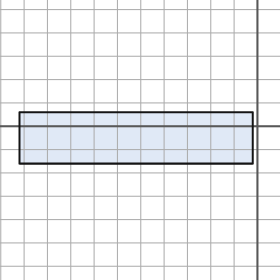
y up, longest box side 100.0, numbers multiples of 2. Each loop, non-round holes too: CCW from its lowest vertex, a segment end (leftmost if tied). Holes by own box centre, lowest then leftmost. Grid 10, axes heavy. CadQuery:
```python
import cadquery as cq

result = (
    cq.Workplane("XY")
    .moveTo(-102.0, -16.0)
    .lineTo(-2.0, -16.0)
    .lineTo(-2.0, 6.0)
    .lineTo(-102.0, 6.0)
    .close()
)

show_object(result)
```